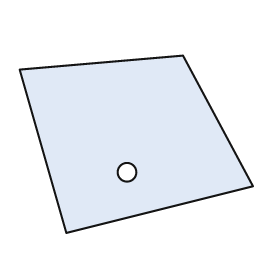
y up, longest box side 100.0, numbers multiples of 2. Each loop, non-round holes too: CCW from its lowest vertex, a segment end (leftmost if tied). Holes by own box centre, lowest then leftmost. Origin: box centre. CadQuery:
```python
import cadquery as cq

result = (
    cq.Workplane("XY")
    .moveTo(-30.0, -38.0)
    .lineTo(50.0, -18.0)
    .lineTo(20.0, 38.0)
    .lineTo(-50.0, 32.0)
    .close()
    .moveTo(-4.0, -12.0)
    .circle(4.0)
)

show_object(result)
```